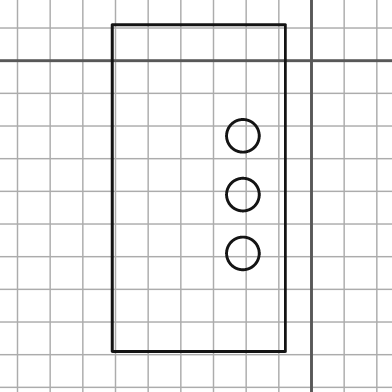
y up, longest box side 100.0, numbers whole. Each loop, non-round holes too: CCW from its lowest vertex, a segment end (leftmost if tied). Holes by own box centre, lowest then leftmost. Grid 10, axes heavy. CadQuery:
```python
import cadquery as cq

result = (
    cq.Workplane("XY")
    .moveTo(-61.0, -89.0)
    .lineTo(-8.0, -89.0)
    .lineTo(-8.0, 11.0)
    .lineTo(-61.0, 11.0)
    .close()
    .moveTo(-21.0, -59.0)
    .circle(5.0)
    .moveTo(-21.0, -41.0)
    .circle(5.0)
    .moveTo(-21.0, -23.0)
    .circle(5.0)
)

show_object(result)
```